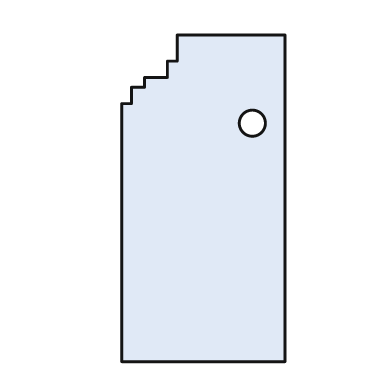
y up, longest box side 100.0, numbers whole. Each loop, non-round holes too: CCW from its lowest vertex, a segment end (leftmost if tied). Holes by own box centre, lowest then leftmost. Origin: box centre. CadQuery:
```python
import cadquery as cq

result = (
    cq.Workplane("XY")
    .moveTo(-25.0, -50.0)
    .lineTo(25.0, -50.0)
    .lineTo(25.0, 50.0)
    .lineTo(-8.0, 50.0)
    .lineTo(-8.0, 42.0)
    .lineTo(-11.0, 42.0)
    .lineTo(-11.0, 37.0)
    .lineTo(-18.0, 37.0)
    .lineTo(-18.0, 34.0)
    .lineTo(-22.0, 34.0)
    .lineTo(-22.0, 29.0)
    .lineTo(-25.0, 29.0)
    .close()
    .moveTo(15.0, 23.0)
    .circle(4.0)
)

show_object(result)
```